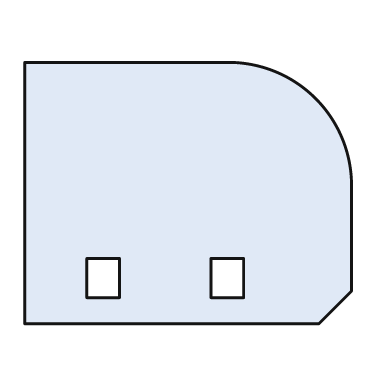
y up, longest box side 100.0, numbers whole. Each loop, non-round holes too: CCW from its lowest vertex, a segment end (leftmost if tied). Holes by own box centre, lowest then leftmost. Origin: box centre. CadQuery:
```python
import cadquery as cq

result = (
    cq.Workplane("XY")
    .moveTo(-50.0, -40.0)
    .lineTo(40.0, -40.0)
    .lineTo(50.0, -30.0)
    .lineTo(50.0, 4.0)
    .threePointArc((39.0, 29.0), (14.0, 40.0))
    .lineTo(-50.0, 40.0)
    .close()
    .moveTo(-31.0, -32.0)
    .lineTo(-21.0, -32.0)
    .lineTo(-21.0, -20.0)
    .lineTo(-31.0, -20.0)
    .close()
    .moveTo(7.0, -32.0)
    .lineTo(17.0, -32.0)
    .lineTo(17.0, -20.0)
    .lineTo(7.0, -20.0)
    .close()
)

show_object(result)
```